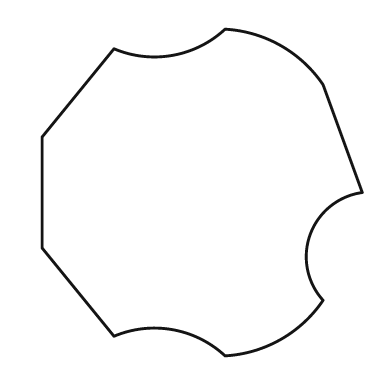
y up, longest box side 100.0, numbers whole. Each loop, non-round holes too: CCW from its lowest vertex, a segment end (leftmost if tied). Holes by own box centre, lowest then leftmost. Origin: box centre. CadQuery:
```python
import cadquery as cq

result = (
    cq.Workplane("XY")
    .moveTo(7.0, -50.0)
    .threePointArc((24.0, -45.0), (37.0, -33.0))
    .threePointArc((33.0, -13.0), (49.0, 0.0))
    .lineTo(37.0, 33.0)
    .threePointArc((24.0, 45.0), (7.0, 50.0))
    .threePointArc((-9.0, 42.0), (-27.0, 44.0))
    .lineTo(-49.0, 17.0)
    .lineTo(-49.0, -17.0)
    .lineTo(-27.0, -44.0)
    .threePointArc((-9.0, -42.0), (7.0, -50.0))
    .close()
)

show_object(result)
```